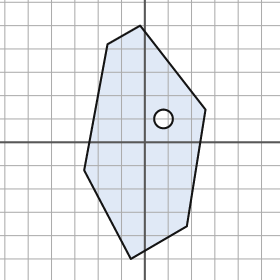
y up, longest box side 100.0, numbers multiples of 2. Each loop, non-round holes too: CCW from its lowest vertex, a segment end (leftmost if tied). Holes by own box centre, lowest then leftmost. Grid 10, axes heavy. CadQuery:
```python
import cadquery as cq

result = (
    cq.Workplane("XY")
    .moveTo(-6.0, -50.0)
    .lineTo(18.0, -36.0)
    .lineTo(26.0, 14.0)
    .lineTo(-2.0, 50.0)
    .lineTo(-16.0, 42.0)
    .lineTo(-26.0, -12.0)
    .close()
    .moveTo(8.0, 10.0)
    .circle(4.0)
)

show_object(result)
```